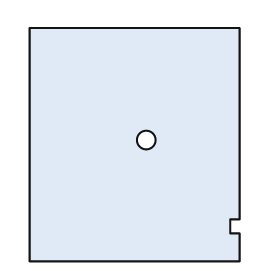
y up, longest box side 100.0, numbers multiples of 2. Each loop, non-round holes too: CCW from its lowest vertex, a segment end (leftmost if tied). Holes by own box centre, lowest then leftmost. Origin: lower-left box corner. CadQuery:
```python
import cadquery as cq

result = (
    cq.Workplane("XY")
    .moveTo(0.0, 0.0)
    .lineTo(90.0, 0.0)
    .lineTo(90.0, 12.0)
    .lineTo(86.0, 12.0)
    .lineTo(86.0, 18.0)
    .lineTo(90.0, 18.0)
    .lineTo(90.0, 100.0)
    .lineTo(0.0, 100.0)
    .close()
    .moveTo(50.0, 52.0)
    .circle(4.0)
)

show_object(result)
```